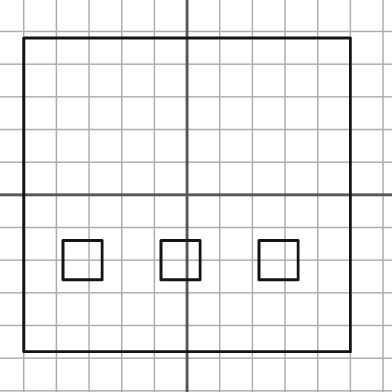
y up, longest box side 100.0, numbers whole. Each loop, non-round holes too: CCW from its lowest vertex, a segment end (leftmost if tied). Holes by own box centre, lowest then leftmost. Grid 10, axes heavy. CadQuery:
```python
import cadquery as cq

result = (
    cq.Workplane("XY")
    .moveTo(-50.0, -48.0)
    .lineTo(50.0, -48.0)
    .lineTo(50.0, 48.0)
    .lineTo(-50.0, 48.0)
    .close()
    .moveTo(-38.0, -26.0)
    .lineTo(-26.0, -26.0)
    .lineTo(-26.0, -14.0)
    .lineTo(-38.0, -14.0)
    .close()
    .moveTo(-8.0, -26.0)
    .lineTo(4.0, -26.0)
    .lineTo(4.0, -14.0)
    .lineTo(-8.0, -14.0)
    .close()
    .moveTo(22.0, -26.0)
    .lineTo(34.0, -26.0)
    .lineTo(34.0, -14.0)
    .lineTo(22.0, -14.0)
    .close()
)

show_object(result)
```